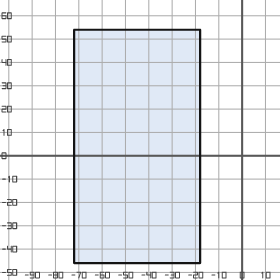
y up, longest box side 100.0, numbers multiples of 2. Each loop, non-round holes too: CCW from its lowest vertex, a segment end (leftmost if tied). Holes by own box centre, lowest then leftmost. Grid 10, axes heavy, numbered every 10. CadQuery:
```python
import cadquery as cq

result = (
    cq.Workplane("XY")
    .moveTo(-72.0, -46.0)
    .lineTo(-18.0, -46.0)
    .lineTo(-18.0, 54.0)
    .lineTo(-72.0, 54.0)
    .close()
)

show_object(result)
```